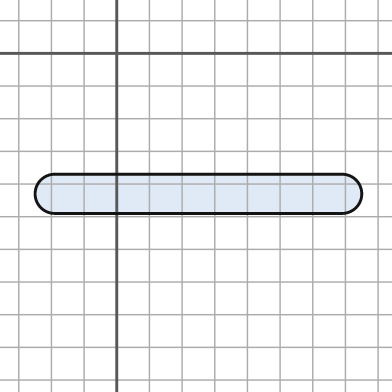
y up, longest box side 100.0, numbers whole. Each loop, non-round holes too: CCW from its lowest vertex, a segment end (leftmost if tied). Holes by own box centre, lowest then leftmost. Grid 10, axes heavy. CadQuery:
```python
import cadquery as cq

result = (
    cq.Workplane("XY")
    .moveTo(-19.0, -49.0)
    .lineTo(69.0, -49.0)
    .threePointArc((75.0, -43.0), (69.0, -37.0))
    .lineTo(-19.0, -37.0)
    .threePointArc((-25.0, -43.0), (-19.0, -49.0))
    .close()
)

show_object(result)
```